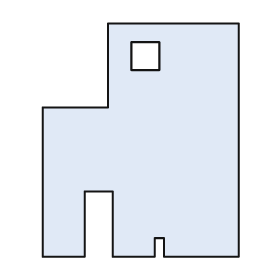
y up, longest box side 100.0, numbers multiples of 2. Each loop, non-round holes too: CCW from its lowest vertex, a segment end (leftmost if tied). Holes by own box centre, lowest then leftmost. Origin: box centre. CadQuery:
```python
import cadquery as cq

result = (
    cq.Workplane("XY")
    .moveTo(-42.0, -50.0)
    .lineTo(-24.0, -50.0)
    .lineTo(-24.0, -22.0)
    .lineTo(-12.0, -22.0)
    .lineTo(-12.0, -50.0)
    .lineTo(6.0, -50.0)
    .lineTo(6.0, -42.0)
    .lineTo(10.0, -42.0)
    .lineTo(10.0, -50.0)
    .lineTo(42.0, -50.0)
    .lineTo(42.0, 50.0)
    .lineTo(-14.0, 50.0)
    .lineTo(-14.0, 14.0)
    .lineTo(-42.0, 14.0)
    .close()
    .moveTo(-4.0, 30.0)
    .lineTo(8.0, 30.0)
    .lineTo(8.0, 42.0)
    .lineTo(-4.0, 42.0)
    .close()
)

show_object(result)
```